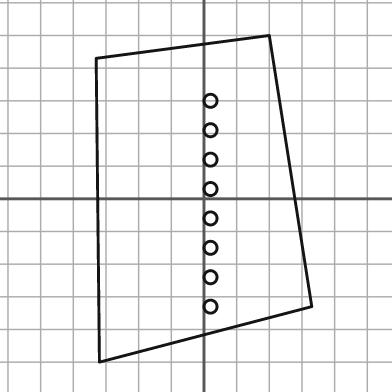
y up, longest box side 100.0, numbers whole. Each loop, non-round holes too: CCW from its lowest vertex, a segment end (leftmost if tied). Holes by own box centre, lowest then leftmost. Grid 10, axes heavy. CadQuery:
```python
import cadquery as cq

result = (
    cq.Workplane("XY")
    .moveTo(-32.0, -50.0)
    .lineTo(33.0, -33.0)
    .lineTo(20.0, 50.0)
    .lineTo(-33.0, 43.0)
    .close()
    .moveTo(2.0, -33.0)
    .circle(2.0)
    .moveTo(2.0, -24.0)
    .circle(2.0)
    .moveTo(2.0, -15.0)
    .circle(2.0)
    .moveTo(2.0, -6.0)
    .circle(2.0)
    .moveTo(2.0, 3.0)
    .circle(2.0)
    .moveTo(2.0, 12.0)
    .circle(2.0)
    .moveTo(2.0, 21.0)
    .circle(2.0)
    .moveTo(2.0, 30.0)
    .circle(2.0)
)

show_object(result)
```